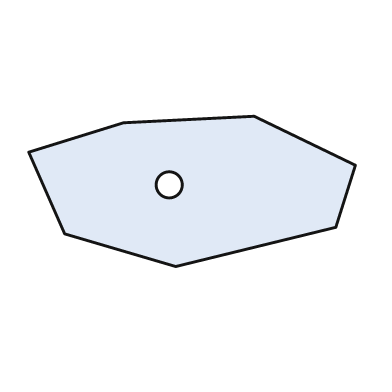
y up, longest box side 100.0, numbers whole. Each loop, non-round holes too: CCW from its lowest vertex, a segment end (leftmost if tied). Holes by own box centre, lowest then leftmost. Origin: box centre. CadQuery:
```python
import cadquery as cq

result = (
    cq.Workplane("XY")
    .moveTo(-5.0, -23.0)
    .lineTo(44.0, -11.0)
    .lineTo(50.0, 8.0)
    .lineTo(19.0, 23.0)
    .lineTo(-21.0, 21.0)
    .lineTo(-50.0, 12.0)
    .lineTo(-39.0, -13.0)
    .close()
    .moveTo(-7.0, 2.0)
    .circle(4.0)
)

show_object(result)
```